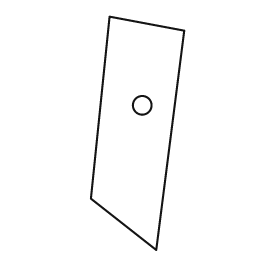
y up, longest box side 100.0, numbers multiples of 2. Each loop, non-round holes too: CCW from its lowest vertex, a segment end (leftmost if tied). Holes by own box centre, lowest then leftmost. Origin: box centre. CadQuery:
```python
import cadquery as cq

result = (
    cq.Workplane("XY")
    .moveTo(8.0, -50.0)
    .lineTo(20.0, 44.0)
    .lineTo(-12.0, 50.0)
    .lineTo(-20.0, -28.0)
    .close()
    .moveTo(2.0, 12.0)
    .circle(4.0)
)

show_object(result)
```